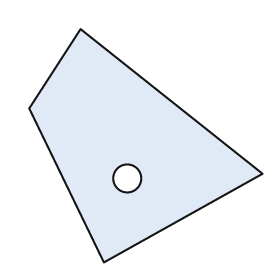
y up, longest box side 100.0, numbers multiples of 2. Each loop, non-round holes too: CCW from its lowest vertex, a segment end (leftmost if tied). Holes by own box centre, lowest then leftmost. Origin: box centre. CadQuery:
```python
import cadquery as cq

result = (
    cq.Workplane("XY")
    .moveTo(-18.0, -50.0)
    .lineTo(50.0, -12.0)
    .lineTo(-28.0, 50.0)
    .lineTo(-50.0, 16.0)
    .close()
    .moveTo(-8.0, -14.0)
    .circle(6.0)
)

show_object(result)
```